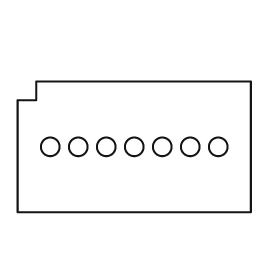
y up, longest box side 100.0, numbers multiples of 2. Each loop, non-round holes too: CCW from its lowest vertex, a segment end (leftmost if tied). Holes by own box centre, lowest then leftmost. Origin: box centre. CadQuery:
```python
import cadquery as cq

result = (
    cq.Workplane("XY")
    .moveTo(-50.0, -28.0)
    .lineTo(50.0, -28.0)
    .lineTo(50.0, 28.0)
    .lineTo(-42.0, 28.0)
    .lineTo(-42.0, 20.0)
    .lineTo(-50.0, 20.0)
    .close()
    .moveTo(-36.0, 0.0)
    .circle(4.0)
    .moveTo(-24.0, 0.0)
    .circle(4.0)
    .moveTo(-12.0, 0.0)
    .circle(4.0)
    .moveTo(0.0, 0.0)
    .circle(4.0)
    .moveTo(12.0, 0.0)
    .circle(4.0)
    .moveTo(24.0, 0.0)
    .circle(4.0)
    .moveTo(36.0, 0.0)
    .circle(4.0)
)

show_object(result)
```